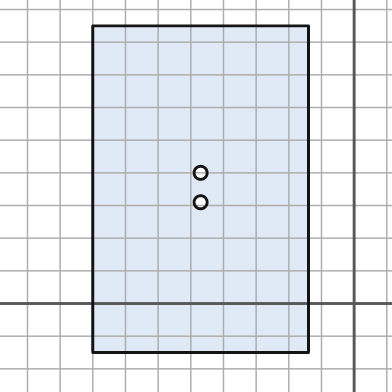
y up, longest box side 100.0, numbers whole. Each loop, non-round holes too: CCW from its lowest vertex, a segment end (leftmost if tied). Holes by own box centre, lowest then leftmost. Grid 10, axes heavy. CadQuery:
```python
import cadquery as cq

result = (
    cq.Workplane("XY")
    .moveTo(-80.0, -15.0)
    .lineTo(-14.0, -15.0)
    .lineTo(-14.0, 85.0)
    .lineTo(-80.0, 85.0)
    .close()
    .moveTo(-47.0, 31.0)
    .circle(2.0)
    .moveTo(-47.0, 40.0)
    .circle(2.0)
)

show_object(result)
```